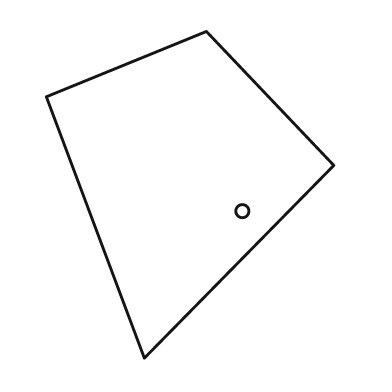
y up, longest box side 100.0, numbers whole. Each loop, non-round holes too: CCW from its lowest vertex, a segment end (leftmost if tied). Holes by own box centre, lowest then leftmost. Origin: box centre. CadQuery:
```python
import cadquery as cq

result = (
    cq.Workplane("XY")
    .moveTo(-14.0, -50.0)
    .lineTo(44.0, 9.0)
    .lineTo(5.0, 50.0)
    .lineTo(-44.0, 30.0)
    .close()
    .moveTo(16.0, -5.0)
    .circle(2.0)
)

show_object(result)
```